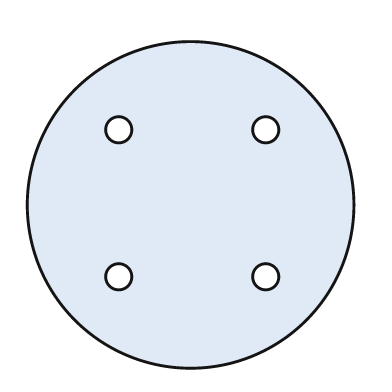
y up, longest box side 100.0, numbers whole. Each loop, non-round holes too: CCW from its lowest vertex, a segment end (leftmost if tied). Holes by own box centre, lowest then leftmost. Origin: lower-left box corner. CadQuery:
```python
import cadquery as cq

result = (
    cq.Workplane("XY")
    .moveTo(50.0, 50.0)
    .circle(50.0)
    .moveTo(28.0, 28.0)
    .circle(4.0)
    .moveTo(73.0, 28.0)
    .circle(4.0)
    .moveTo(28.0, 73.0)
    .circle(4.0)
    .moveTo(73.0, 73.0)
    .circle(4.0)
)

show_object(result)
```